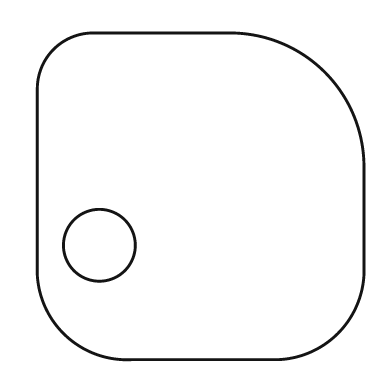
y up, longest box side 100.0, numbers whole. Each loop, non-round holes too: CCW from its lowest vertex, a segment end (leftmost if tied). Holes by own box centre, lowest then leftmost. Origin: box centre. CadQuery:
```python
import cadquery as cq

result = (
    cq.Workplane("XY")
    .moveTo(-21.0, -50.0)
    .lineTo(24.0, -50.0)
    .threePointArc((42.0, -42.0), (50.0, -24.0))
    .lineTo(50.0, 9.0)
    .threePointArc((38.0, 38.0), (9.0, 50.0))
    .lineTo(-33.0, 50.0)
    .threePointArc((-45.0, 45.0), (-50.0, 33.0))
    .lineTo(-50.0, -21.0)
    .threePointArc((-42.0, -42.0), (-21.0, -50.0))
    .close()
    .moveTo(-31.0, -15.0)
    .circle(11.0)
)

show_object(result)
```